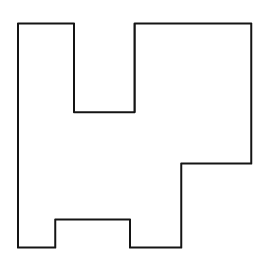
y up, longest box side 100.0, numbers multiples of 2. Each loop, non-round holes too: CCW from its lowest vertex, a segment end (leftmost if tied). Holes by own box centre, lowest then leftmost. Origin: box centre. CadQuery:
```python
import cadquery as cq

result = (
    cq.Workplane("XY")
    .moveTo(-50.0, -48.0)
    .lineTo(-34.0, -48.0)
    .lineTo(-34.0, -36.0)
    .lineTo(-2.0, -36.0)
    .lineTo(-2.0, -48.0)
    .lineTo(20.0, -48.0)
    .lineTo(20.0, -12.0)
    .lineTo(50.0, -12.0)
    .lineTo(50.0, 48.0)
    .lineTo(0.0, 48.0)
    .lineTo(0.0, 10.0)
    .lineTo(-26.0, 10.0)
    .lineTo(-26.0, 48.0)
    .lineTo(-50.0, 48.0)
    .close()
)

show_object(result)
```